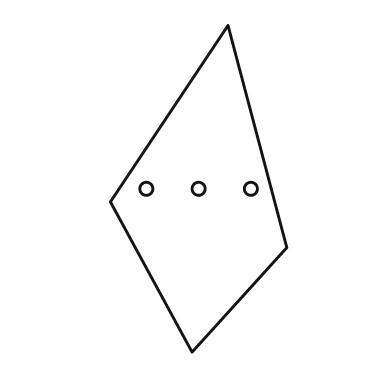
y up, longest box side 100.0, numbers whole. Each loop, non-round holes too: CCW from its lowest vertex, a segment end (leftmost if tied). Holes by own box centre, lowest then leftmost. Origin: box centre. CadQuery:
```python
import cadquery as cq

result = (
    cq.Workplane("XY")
    .moveTo(-2.0, -50.0)
    .lineTo(27.0, -18.0)
    .lineTo(9.0, 50.0)
    .lineTo(-27.0, -4.0)
    .close()
    .moveTo(-16.0, 0.0)
    .circle(2.0)
    .moveTo(0.0, 0.0)
    .circle(2.0)
    .moveTo(16.0, 0.0)
    .circle(2.0)
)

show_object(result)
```